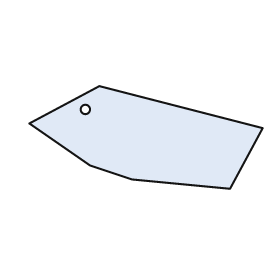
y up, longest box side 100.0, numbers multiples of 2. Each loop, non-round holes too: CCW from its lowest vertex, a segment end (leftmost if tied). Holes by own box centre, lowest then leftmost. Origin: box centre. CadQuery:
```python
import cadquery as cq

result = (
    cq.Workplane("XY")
    .moveTo(36.0, -22.0)
    .lineTo(50.0, 4.0)
    .lineTo(-20.0, 22.0)
    .lineTo(-50.0, 6.0)
    .lineTo(-24.0, -12.0)
    .lineTo(-6.0, -18.0)
    .close()
    .moveTo(-26.0, 12.0)
    .circle(2.0)
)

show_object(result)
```